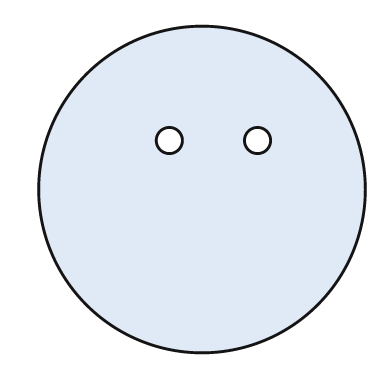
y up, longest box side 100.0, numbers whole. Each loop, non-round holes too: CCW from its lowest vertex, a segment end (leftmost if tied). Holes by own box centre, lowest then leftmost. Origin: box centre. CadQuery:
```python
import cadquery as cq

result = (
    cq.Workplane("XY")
    .moveTo(0.0, 0.0)
    .circle(50.0)
    .moveTo(-10.0, 15.0)
    .circle(4.0)
    .moveTo(17.0, 15.0)
    .circle(4.0)
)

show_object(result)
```